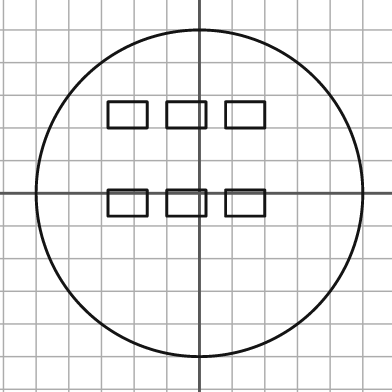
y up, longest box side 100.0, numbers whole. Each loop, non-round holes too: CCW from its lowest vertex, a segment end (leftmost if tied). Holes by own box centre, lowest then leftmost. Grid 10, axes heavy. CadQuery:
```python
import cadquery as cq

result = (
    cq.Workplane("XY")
    .moveTo(0.0, 0.0)
    .circle(50.0)
    .moveTo(-28.0, -7.0)
    .lineTo(-16.0, -7.0)
    .lineTo(-16.0, 1.0)
    .lineTo(-28.0, 1.0)
    .close()
    .moveTo(-10.0, -7.0)
    .lineTo(2.0, -7.0)
    .lineTo(2.0, 1.0)
    .lineTo(-10.0, 1.0)
    .close()
    .moveTo(8.0, -7.0)
    .lineTo(20.0, -7.0)
    .lineTo(20.0, 1.0)
    .lineTo(8.0, 1.0)
    .close()
    .moveTo(-28.0, 20.0)
    .lineTo(-16.0, 20.0)
    .lineTo(-16.0, 28.0)
    .lineTo(-28.0, 28.0)
    .close()
    .moveTo(-10.0, 20.0)
    .lineTo(2.0, 20.0)
    .lineTo(2.0, 28.0)
    .lineTo(-10.0, 28.0)
    .close()
    .moveTo(8.0, 20.0)
    .lineTo(20.0, 20.0)
    .lineTo(20.0, 28.0)
    .lineTo(8.0, 28.0)
    .close()
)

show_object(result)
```